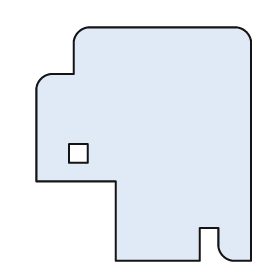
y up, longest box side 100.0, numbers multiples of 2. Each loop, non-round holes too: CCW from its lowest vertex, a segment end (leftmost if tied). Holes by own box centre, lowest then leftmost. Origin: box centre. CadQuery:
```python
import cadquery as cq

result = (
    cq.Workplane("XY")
    .moveTo(-12.0, -50.0)
    .lineTo(24.0, -50.0)
    .lineTo(24.0, -36.0)
    .lineTo(32.0, -36.0)
    .lineTo(32.0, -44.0)
    .threePointArc((34.0, -48.0), (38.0, -50.0))
    .lineTo(46.0, -50.0)
    .lineTo(46.0, 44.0)
    .threePointArc((44.0, 48.0), (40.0, 50.0))
    .lineTo(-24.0, 50.0)
    .threePointArc((-28.0, 48.0), (-30.0, 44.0))
    .lineTo(-30.0, 30.0)
    .lineTo(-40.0, 30.0)
    .threePointArc((-44.0, 28.0), (-46.0, 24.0))
    .lineTo(-46.0, -16.0)
    .lineTo(-12.0, -16.0)
    .close()
    .moveTo(-32.0, -8.0)
    .lineTo(-24.0, -8.0)
    .lineTo(-24.0, 0.0)
    .lineTo(-32.0, 0.0)
    .close()
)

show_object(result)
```